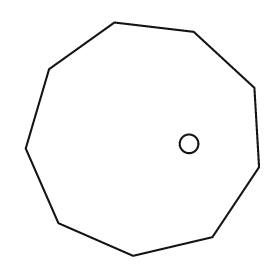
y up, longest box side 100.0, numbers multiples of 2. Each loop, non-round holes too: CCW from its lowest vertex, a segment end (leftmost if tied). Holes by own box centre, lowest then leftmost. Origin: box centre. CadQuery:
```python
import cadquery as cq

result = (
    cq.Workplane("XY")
    .moveTo(-4.0, -50.0)
    .lineTo(30.0, -42.0)
    .lineTo(50.0, -12.0)
    .lineTo(48.0, 22.0)
    .lineTo(22.0, 46.0)
    .lineTo(-12.0, 50.0)
    .lineTo(-40.0, 30.0)
    .lineTo(-50.0, -4.0)
    .lineTo(-36.0, -36.0)
    .close()
    .moveTo(20.0, -2.0)
    .circle(4.0)
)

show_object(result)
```